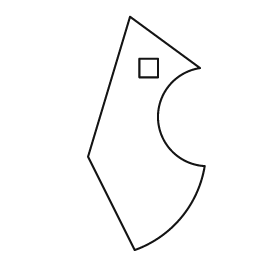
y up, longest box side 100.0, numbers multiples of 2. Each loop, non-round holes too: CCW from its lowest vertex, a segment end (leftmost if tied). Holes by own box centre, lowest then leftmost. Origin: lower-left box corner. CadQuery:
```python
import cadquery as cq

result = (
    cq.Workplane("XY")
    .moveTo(20.0, 0.0)
    .threePointArc((40.0, 14.0), (50.0, 36.0))
    .threePointArc((30.0, 56.0), (48.0, 78.0))
    .lineTo(18.0, 100.0)
    .lineTo(0.0, 40.0)
    .close()
    .moveTo(22.0, 74.0)
    .lineTo(30.0, 74.0)
    .lineTo(30.0, 82.0)
    .lineTo(22.0, 82.0)
    .close()
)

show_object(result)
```